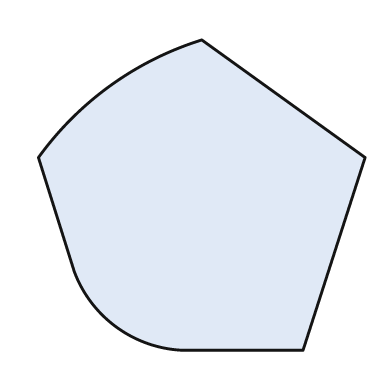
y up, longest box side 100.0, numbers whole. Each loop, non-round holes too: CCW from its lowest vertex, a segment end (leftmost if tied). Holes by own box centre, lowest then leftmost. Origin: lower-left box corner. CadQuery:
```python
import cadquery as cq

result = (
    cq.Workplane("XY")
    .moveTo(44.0, 0.0)
    .lineTo(81.0, 0.0)
    .lineTo(100.0, 59.0)
    .lineTo(50.0, 95.0)
    .threePointArc((22.0, 81.0), (0.0, 59.0))
    .lineTo(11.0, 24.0)
    .threePointArc((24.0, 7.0), (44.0, 0.0))
    .close()
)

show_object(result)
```